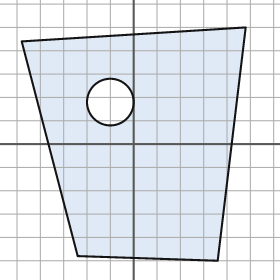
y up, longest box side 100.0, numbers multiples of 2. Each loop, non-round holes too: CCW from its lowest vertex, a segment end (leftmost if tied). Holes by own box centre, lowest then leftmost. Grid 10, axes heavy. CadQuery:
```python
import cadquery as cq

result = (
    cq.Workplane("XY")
    .moveTo(36.0, -50.0)
    .lineTo(48.0, 50.0)
    .lineTo(-48.0, 44.0)
    .lineTo(-24.0, -48.0)
    .close()
    .moveTo(-10.0, 18.0)
    .circle(10.0)
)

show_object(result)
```